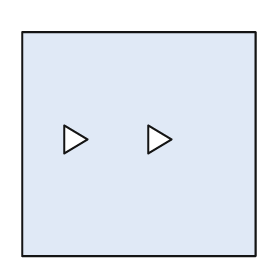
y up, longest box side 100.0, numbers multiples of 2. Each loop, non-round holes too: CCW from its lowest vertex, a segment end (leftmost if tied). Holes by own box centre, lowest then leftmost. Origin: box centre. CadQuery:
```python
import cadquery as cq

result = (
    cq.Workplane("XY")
    .moveTo(-50.0, -48.0)
    .lineTo(50.0, -48.0)
    .lineTo(50.0, 48.0)
    .lineTo(-50.0, 48.0)
    .close()
    .moveTo(-32.0, -4.0)
    .lineTo(-22.0, 2.0)
    .lineTo(-32.0, 8.0)
    .close()
    .moveTo(4.0, -4.0)
    .lineTo(14.0, 2.0)
    .lineTo(4.0, 8.0)
    .close()
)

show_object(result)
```